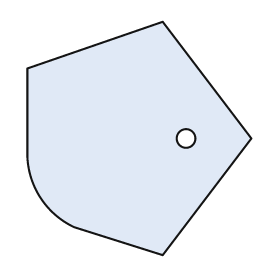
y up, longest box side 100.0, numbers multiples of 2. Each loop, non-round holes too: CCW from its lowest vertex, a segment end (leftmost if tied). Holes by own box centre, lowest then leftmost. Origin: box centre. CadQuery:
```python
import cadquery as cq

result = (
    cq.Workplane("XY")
    .moveTo(10.0, -50.0)
    .lineTo(48.0, 0.0)
    .lineTo(10.0, 50.0)
    .lineTo(-48.0, 30.0)
    .lineTo(-48.0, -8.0)
    .threePointArc((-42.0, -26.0), (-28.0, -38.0))
    .close()
    .moveTo(20.0, 0.0)
    .circle(4.0)
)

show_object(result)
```